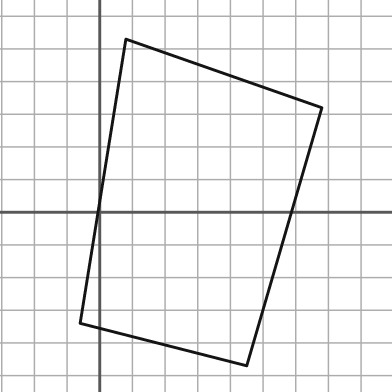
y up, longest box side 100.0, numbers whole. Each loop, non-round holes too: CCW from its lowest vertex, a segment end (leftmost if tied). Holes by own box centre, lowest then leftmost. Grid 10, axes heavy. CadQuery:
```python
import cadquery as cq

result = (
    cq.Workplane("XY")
    .moveTo(45.0, -47.0)
    .lineTo(68.0, 32.0)
    .lineTo(8.0, 53.0)
    .lineTo(-6.0, -34.0)
    .close()
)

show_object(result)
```